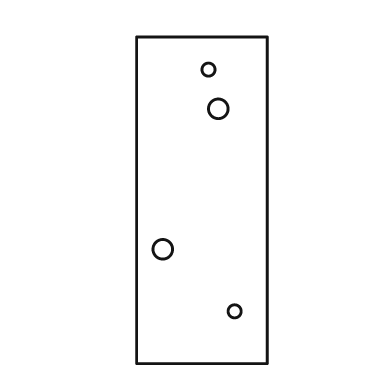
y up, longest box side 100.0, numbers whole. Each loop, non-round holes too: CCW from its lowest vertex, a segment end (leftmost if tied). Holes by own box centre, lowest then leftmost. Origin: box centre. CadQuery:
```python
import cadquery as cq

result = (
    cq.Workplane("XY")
    .moveTo(-20.0, -50.0)
    .lineTo(20.0, -50.0)
    .lineTo(20.0, 50.0)
    .lineTo(-20.0, 50.0)
    .close()
    .moveTo(10.0, -34.0)
    .circle(2.0)
    .moveTo(-12.0, -15.0)
    .circle(3.0)
    .moveTo(5.0, 28.0)
    .circle(3.0)
    .moveTo(2.0, 40.0)
    .circle(2.0)
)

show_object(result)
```